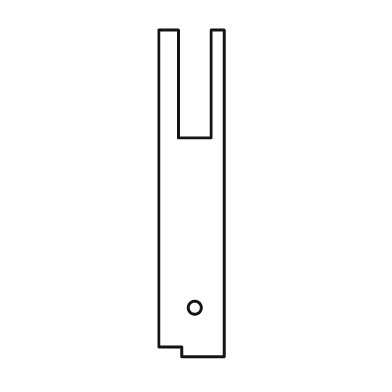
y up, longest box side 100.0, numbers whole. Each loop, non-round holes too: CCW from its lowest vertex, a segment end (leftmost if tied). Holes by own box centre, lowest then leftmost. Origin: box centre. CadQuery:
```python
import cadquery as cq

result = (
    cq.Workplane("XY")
    .moveTo(-3.0, -50.0)
    .lineTo(10.0, -50.0)
    .lineTo(10.0, 50.0)
    .lineTo(6.0, 50.0)
    .lineTo(6.0, 17.0)
    .lineTo(-4.0, 17.0)
    .lineTo(-4.0, 50.0)
    .lineTo(-10.0, 50.0)
    .lineTo(-10.0, -47.0)
    .lineTo(-3.0, -47.0)
    .close()
    .moveTo(1.0, -35.0)
    .circle(2.0)
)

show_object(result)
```